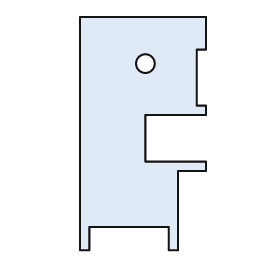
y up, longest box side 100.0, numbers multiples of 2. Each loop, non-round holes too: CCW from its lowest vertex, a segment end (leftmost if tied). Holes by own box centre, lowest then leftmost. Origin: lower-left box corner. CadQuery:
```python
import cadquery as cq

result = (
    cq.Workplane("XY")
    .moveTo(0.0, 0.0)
    .lineTo(4.0, 0.0)
    .lineTo(4.0, 10.0)
    .lineTo(38.0, 10.0)
    .lineTo(38.0, 0.0)
    .lineTo(42.0, 0.0)
    .lineTo(42.0, 34.0)
    .lineTo(54.0, 34.0)
    .lineTo(54.0, 38.0)
    .lineTo(28.0, 38.0)
    .lineTo(28.0, 58.0)
    .lineTo(54.0, 58.0)
    .lineTo(54.0, 62.0)
    .lineTo(50.0, 62.0)
    .lineTo(50.0, 86.0)
    .lineTo(54.0, 86.0)
    .lineTo(54.0, 100.0)
    .lineTo(0.0, 100.0)
    .close()
    .moveTo(28.0, 80.0)
    .circle(4.0)
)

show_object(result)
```